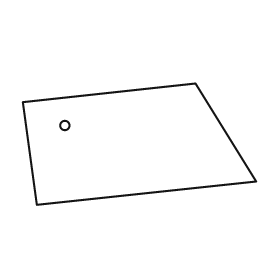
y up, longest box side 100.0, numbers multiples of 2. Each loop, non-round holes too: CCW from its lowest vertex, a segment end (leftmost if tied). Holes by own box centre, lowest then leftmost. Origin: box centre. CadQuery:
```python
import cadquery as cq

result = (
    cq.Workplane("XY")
    .moveTo(-44.0, -26.0)
    .lineTo(50.0, -16.0)
    .lineTo(24.0, 26.0)
    .lineTo(-50.0, 18.0)
    .close()
    .moveTo(-32.0, 8.0)
    .circle(2.0)
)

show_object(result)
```